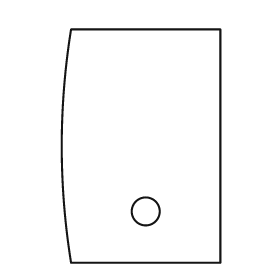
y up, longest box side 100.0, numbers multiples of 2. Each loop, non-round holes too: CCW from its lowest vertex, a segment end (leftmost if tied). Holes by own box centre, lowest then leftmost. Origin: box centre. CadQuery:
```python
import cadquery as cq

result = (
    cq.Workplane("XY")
    .moveTo(-30.0, -50.0)
    .lineTo(34.0, -50.0)
    .lineTo(34.0, 50.0)
    .lineTo(-30.0, 50.0)
    .threePointArc((-34.0, 0.0), (-30.0, -50.0))
    .close()
    .moveTo(2.0, -28.0)
    .circle(6.0)
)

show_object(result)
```